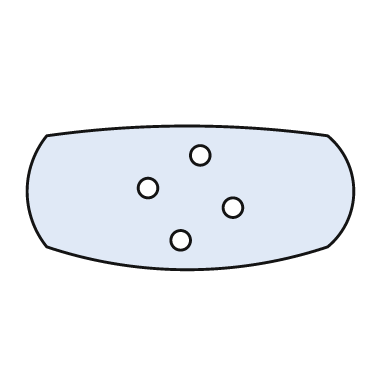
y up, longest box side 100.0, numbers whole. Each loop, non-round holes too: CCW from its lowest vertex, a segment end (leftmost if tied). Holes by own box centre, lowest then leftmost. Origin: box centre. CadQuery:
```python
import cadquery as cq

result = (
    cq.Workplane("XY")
    .moveTo(-44.0, -15.0)
    .threePointArc((-1.0, -22.0), (42.0, -15.0))
    .threePointArc((50.0, 2.0), (42.0, 19.0))
    .threePointArc((-1.0, 22.0), (-44.0, 19.0))
    .threePointArc((-50.0, 2.0), (-44.0, -15.0))
    .close()
    .moveTo(-3.0, -13.0)
    .circle(3.0)
    .moveTo(13.0, -3.0)
    .circle(3.0)
    .moveTo(-13.0, 3.0)
    .circle(3.0)
    .moveTo(3.0, 13.0)
    .circle(3.0)
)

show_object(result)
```